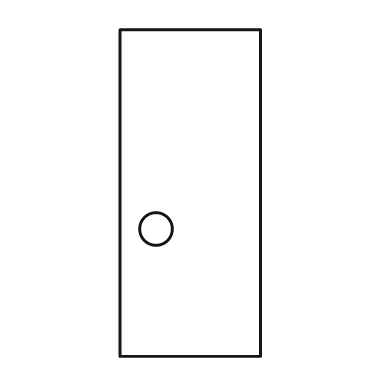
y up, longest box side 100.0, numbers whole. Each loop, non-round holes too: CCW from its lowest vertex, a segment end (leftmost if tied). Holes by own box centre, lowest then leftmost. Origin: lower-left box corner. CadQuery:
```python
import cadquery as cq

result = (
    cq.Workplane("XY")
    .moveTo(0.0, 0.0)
    .lineTo(43.0, 0.0)
    .lineTo(43.0, 100.0)
    .lineTo(0.0, 100.0)
    .close()
    .moveTo(11.0, 39.0)
    .circle(5.0)
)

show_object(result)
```